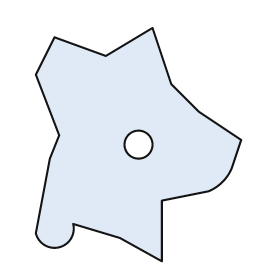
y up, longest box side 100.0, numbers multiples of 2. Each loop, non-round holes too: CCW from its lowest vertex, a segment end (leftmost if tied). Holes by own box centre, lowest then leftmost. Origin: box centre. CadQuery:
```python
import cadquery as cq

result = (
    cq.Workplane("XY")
    .moveTo(10.0, -50.0)
    .lineTo(10.0, -24.0)
    .lineTo(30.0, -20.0)
    .threePointArc((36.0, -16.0), (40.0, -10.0))
    .lineTo(44.0, 2.0)
    .lineTo(26.0, 14.0)
    .lineTo(14.0, 26.0)
    .lineTo(6.0, 50.0)
    .lineTo(-14.0, 38.0)
    .lineTo(-36.0, 46.0)
    .lineTo(-44.0, 30.0)
    .lineTo(-34.0, 4.0)
    .lineTo(-38.0, -6.0)
    .lineTo(-44.0, -38.0)
    .threePointArc((-34.0, -44.0), (-28.0, -34.0))
    .lineTo(-8.0, -40.0)
    .close()
    .moveTo(0.0, 0.0)
    .circle(6.0)
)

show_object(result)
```